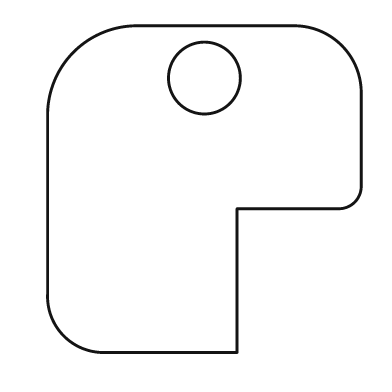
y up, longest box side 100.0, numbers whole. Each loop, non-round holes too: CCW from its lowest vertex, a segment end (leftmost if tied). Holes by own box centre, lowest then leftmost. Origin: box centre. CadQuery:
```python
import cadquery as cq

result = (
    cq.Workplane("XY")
    .moveTo(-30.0, -50.0)
    .lineTo(10.0, -50.0)
    .lineTo(10.0, -6.0)
    .lineTo(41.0, -6.0)
    .threePointArc((46.0, -4.0), (48.0, 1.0))
    .lineTo(48.0, 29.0)
    .threePointArc((42.0, 44.0), (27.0, 50.0))
    .lineTo(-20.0, 50.0)
    .threePointArc((-40.0, 42.0), (-48.0, 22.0))
    .lineTo(-48.0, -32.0)
    .threePointArc((-43.0, -45.0), (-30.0, -50.0))
    .close()
    .moveTo(0.0, 34.0)
    .circle(11.0)
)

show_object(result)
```